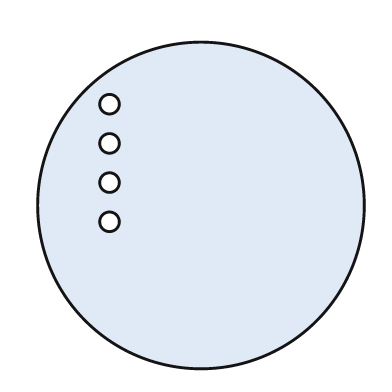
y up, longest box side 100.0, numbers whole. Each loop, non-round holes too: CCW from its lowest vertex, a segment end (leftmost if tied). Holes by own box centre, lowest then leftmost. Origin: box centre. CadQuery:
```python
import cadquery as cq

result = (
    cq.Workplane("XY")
    .moveTo(0.0, 0.0)
    .circle(50.0)
    .moveTo(-28.0, -5.0)
    .circle(3.0)
    .moveTo(-28.0, 7.0)
    .circle(3.0)
    .moveTo(-28.0, 19.0)
    .circle(3.0)
    .moveTo(-28.0, 31.0)
    .circle(3.0)
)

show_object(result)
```